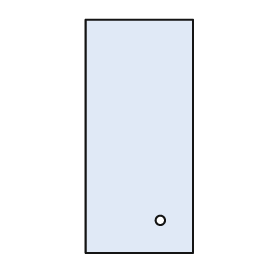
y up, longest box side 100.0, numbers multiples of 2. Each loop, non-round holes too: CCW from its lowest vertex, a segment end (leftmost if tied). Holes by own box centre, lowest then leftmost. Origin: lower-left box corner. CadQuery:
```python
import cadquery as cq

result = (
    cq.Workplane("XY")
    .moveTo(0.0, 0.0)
    .lineTo(46.0, 0.0)
    .lineTo(46.0, 100.0)
    .lineTo(0.0, 100.0)
    .close()
    .moveTo(32.0, 14.0)
    .circle(2.0)
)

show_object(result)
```